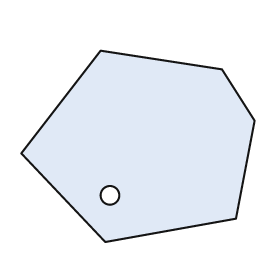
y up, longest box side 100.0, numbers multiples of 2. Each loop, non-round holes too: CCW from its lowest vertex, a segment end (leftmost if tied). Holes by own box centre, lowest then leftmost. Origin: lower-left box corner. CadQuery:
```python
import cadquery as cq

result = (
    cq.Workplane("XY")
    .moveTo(36.0, 0.0)
    .lineTo(92.0, 10.0)
    .lineTo(100.0, 52.0)
    .lineTo(86.0, 74.0)
    .lineTo(34.0, 82.0)
    .lineTo(0.0, 38.0)
    .close()
    .moveTo(38.0, 20.0)
    .circle(4.0)
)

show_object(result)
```